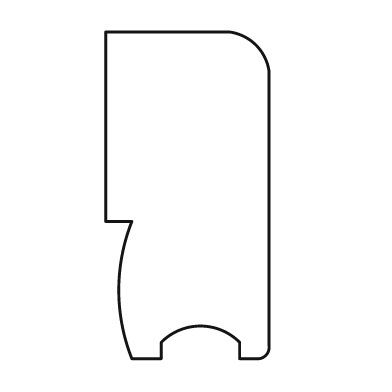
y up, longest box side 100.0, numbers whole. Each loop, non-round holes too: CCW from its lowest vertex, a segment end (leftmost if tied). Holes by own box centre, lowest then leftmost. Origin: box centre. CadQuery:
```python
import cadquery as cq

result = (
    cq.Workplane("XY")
    .moveTo(-17.0, -50.0)
    .lineTo(-8.0, -50.0)
    .lineTo(-8.0, -45.0)
    .threePointArc((4.0, -40.0), (16.0, -45.0))
    .lineTo(16.0, -50.0)
    .lineTo(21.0, -50.0)
    .threePointArc((24.0, -49.0), (25.0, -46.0))
    .lineTo(25.0, 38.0)
    .threePointArc((21.0, 46.0), (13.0, 50.0))
    .lineTo(-25.0, 50.0)
    .lineTo(-25.0, -8.0)
    .lineTo(-17.0, -8.0)
    .threePointArc((-21.0, -29.0), (-17.0, -50.0))
    .close()
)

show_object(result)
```